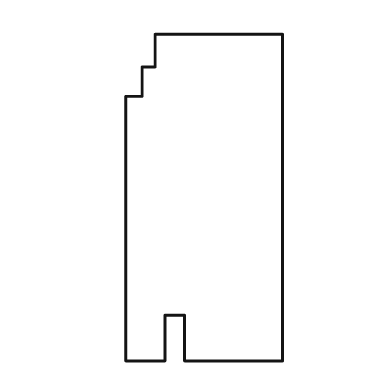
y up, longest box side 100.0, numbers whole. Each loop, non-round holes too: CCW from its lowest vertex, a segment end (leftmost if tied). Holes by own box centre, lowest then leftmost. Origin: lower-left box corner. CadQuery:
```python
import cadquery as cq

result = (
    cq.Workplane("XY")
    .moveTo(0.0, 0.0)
    .lineTo(12.0, 0.0)
    .lineTo(12.0, 14.0)
    .lineTo(18.0, 14.0)
    .lineTo(18.0, 0.0)
    .lineTo(48.0, 0.0)
    .lineTo(48.0, 100.0)
    .lineTo(9.0, 100.0)
    .lineTo(9.0, 90.0)
    .lineTo(5.0, 90.0)
    .lineTo(5.0, 81.0)
    .lineTo(0.0, 81.0)
    .close()
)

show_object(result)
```